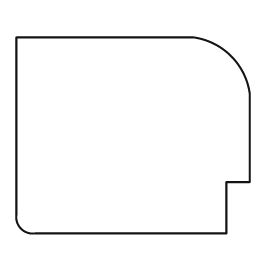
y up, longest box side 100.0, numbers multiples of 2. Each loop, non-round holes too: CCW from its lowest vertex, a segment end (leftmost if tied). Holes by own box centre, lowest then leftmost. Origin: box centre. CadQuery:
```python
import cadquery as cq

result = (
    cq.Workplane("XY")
    .moveTo(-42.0, -42.0)
    .lineTo(40.0, -42.0)
    .lineTo(40.0, -20.0)
    .lineTo(50.0, -20.0)
    .lineTo(50.0, 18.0)
    .threePointArc((42.0, 34.0), (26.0, 42.0))
    .lineTo(-50.0, 42.0)
    .lineTo(-50.0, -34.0)
    .threePointArc((-48.0, -40.0), (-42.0, -42.0))
    .close()
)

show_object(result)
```